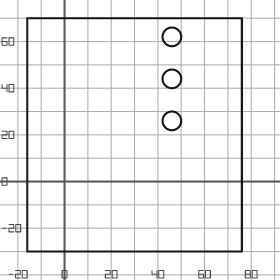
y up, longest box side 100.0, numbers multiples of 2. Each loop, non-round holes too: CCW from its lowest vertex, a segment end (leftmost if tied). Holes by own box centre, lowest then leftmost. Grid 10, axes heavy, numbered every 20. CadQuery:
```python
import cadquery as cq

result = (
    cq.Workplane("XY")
    .moveTo(-16.0, -30.0)
    .lineTo(76.0, -30.0)
    .lineTo(76.0, 70.0)
    .lineTo(-16.0, 70.0)
    .close()
    .moveTo(46.0, 26.0)
    .circle(4.0)
    .moveTo(46.0, 44.0)
    .circle(4.0)
    .moveTo(46.0, 62.0)
    .circle(4.0)
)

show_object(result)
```